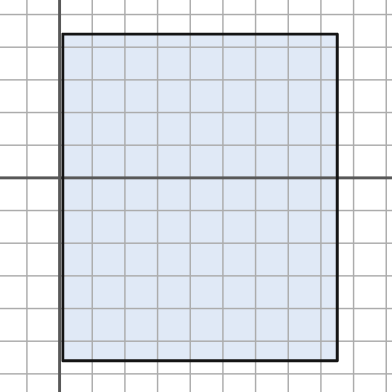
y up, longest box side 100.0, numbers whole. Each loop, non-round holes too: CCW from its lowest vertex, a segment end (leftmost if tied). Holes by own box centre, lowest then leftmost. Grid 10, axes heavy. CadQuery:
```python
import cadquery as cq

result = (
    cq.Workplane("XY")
    .moveTo(1.0, -56.0)
    .lineTo(85.0, -56.0)
    .lineTo(85.0, 44.0)
    .lineTo(1.0, 44.0)
    .close()
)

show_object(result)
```